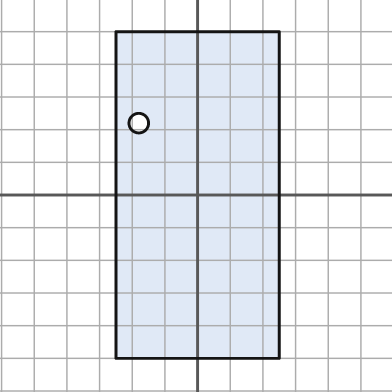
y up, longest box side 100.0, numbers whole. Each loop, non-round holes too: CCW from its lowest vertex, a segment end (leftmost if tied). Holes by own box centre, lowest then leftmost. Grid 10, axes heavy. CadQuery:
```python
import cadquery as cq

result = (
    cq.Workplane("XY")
    .moveTo(-25.0, -50.0)
    .lineTo(25.0, -50.0)
    .lineTo(25.0, 50.0)
    .lineTo(-25.0, 50.0)
    .close()
    .moveTo(-18.0, 22.0)
    .circle(3.0)
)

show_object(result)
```